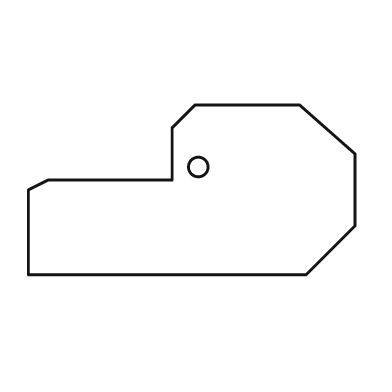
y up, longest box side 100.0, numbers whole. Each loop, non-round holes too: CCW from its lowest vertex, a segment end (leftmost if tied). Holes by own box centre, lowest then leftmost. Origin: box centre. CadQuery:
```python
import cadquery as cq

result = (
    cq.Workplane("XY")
    .moveTo(-50.0, -26.0)
    .lineTo(35.0, -26.0)
    .lineTo(50.0, -11.0)
    .lineTo(50.0, 11.0)
    .lineTo(33.0, 26.0)
    .lineTo(1.0, 26.0)
    .lineTo(-6.0, 19.0)
    .lineTo(-6.0, 3.0)
    .lineTo(-44.0, 3.0)
    .lineTo(-50.0, 0.0)
    .close()
    .moveTo(2.0, 7.0)
    .circle(3.0)
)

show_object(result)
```